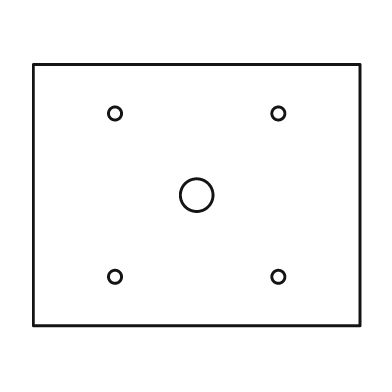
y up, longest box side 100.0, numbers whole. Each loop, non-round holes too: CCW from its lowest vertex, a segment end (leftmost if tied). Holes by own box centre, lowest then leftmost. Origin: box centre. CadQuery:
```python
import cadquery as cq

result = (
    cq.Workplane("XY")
    .moveTo(-50.0, -40.0)
    .lineTo(50.0, -40.0)
    .lineTo(50.0, 40.0)
    .lineTo(-50.0, 40.0)
    .close()
    .moveTo(-25.0, -25.0)
    .circle(2.0)
    .moveTo(25.0, -25.0)
    .circle(2.0)
    .moveTo(0.0, 0.0)
    .circle(5.0)
    .moveTo(-25.0, 25.0)
    .circle(2.0)
    .moveTo(25.0, 25.0)
    .circle(2.0)
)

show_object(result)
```